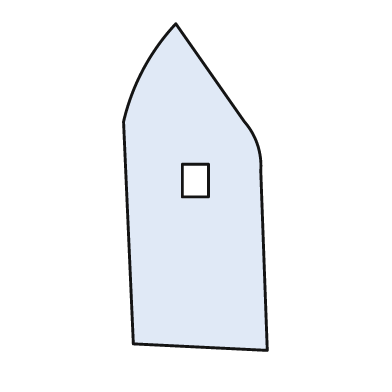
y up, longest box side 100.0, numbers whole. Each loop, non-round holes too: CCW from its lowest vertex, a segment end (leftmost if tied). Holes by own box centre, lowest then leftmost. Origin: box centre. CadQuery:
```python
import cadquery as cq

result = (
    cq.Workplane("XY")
    .moveTo(22.0, -50.0)
    .lineTo(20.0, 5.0)
    .threePointArc((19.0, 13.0), (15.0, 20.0))
    .lineTo(-6.0, 50.0)
    .threePointArc((-16.0, 36.0), (-22.0, 20.0))
    .lineTo(-19.0, -48.0)
    .close()
    .moveTo(-4.0, -3.0)
    .lineTo(4.0, -3.0)
    .lineTo(4.0, 7.0)
    .lineTo(-4.0, 7.0)
    .close()
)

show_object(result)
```